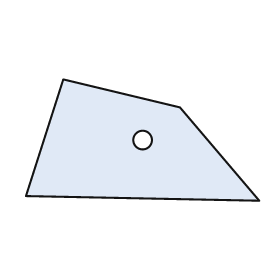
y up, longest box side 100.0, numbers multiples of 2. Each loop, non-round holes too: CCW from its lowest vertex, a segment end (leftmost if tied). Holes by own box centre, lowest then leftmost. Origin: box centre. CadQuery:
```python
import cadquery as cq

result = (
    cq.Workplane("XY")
    .moveTo(50.0, -26.0)
    .lineTo(16.0, 14.0)
    .lineTo(-34.0, 26.0)
    .lineTo(-50.0, -24.0)
    .close()
    .moveTo(0.0, 0.0)
    .circle(4.0)
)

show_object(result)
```